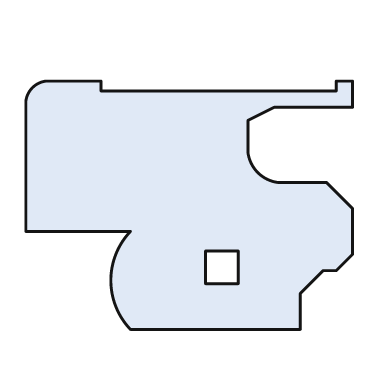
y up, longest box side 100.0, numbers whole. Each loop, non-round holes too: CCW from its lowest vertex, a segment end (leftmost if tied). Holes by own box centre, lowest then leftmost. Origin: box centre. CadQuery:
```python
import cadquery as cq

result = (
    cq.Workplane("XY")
    .moveTo(-18.0, -38.0)
    .lineTo(34.0, -38.0)
    .lineTo(34.0, -27.0)
    .lineTo(41.0, -20.0)
    .lineTo(45.0, -20.0)
    .lineTo(50.0, -15.0)
    .lineTo(50.0, -1.0)
    .lineTo(42.0, 7.0)
    .lineTo(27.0, 7.0)
    .threePointArc((21.0, 10.0), (18.0, 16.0))
    .lineTo(18.0, 26.0)
    .lineTo(26.0, 30.0)
    .lineTo(50.0, 30.0)
    .lineTo(50.0, 38.0)
    .lineTo(45.0, 38.0)
    .lineTo(45.0, 35.0)
    .lineTo(-27.0, 35.0)
    .lineTo(-27.0, 38.0)
    .lineTo(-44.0, 38.0)
    .threePointArc((-48.0, 36.0), (-50.0, 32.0))
    .lineTo(-50.0, -8.0)
    .lineTo(-18.0, -8.0)
    .threePointArc((-24.0, -23.0), (-18.0, -38.0))
    .close()
    .moveTo(5.0, -24.0)
    .lineTo(15.0, -24.0)
    .lineTo(15.0, -14.0)
    .lineTo(5.0, -14.0)
    .close()
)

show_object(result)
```